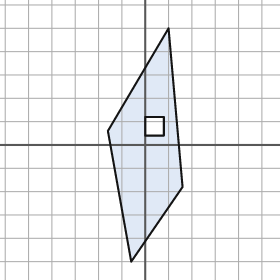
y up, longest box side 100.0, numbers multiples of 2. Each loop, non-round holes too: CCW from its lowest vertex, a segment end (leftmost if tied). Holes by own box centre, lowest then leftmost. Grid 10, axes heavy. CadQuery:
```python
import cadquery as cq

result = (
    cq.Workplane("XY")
    .moveTo(-6.0, -50.0)
    .lineTo(16.0, -18.0)
    .lineTo(10.0, 50.0)
    .lineTo(-16.0, 6.0)
    .close()
    .moveTo(0.0, 4.0)
    .lineTo(8.0, 4.0)
    .lineTo(8.0, 12.0)
    .lineTo(0.0, 12.0)
    .close()
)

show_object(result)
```